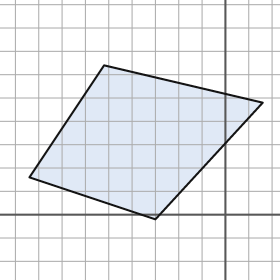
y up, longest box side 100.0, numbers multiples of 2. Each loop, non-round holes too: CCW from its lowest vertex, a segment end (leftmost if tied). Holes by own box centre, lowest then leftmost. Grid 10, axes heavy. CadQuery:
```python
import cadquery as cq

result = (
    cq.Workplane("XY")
    .moveTo(-30.0, -2.0)
    .lineTo(16.0, 48.0)
    .lineTo(-52.0, 64.0)
    .lineTo(-84.0, 16.0)
    .close()
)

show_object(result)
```